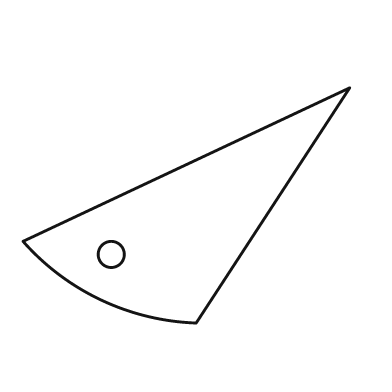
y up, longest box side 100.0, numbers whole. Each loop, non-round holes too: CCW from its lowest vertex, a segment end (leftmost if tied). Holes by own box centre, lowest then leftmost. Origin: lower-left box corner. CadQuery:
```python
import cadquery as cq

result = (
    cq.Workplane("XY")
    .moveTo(53.0, 0.0)
    .lineTo(100.0, 72.0)
    .lineTo(0.0, 25.0)
    .threePointArc((24.0, 7.0), (53.0, 0.0))
    .close()
    .moveTo(27.0, 21.0)
    .circle(4.0)
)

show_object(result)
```